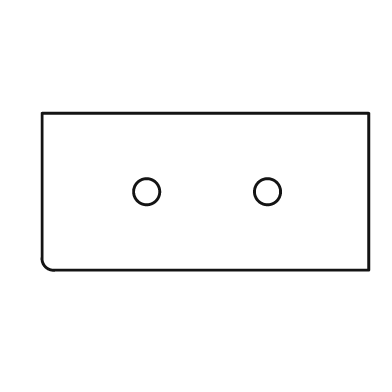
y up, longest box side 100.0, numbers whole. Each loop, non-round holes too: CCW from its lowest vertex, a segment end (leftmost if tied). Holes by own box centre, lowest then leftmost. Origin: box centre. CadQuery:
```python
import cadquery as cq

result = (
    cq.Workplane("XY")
    .moveTo(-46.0, -24.0)
    .lineTo(50.0, -24.0)
    .lineTo(50.0, 24.0)
    .lineTo(-50.0, 24.0)
    .lineTo(-50.0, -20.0)
    .threePointArc((-49.0, -23.0), (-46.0, -24.0))
    .close()
    .moveTo(-18.0, 0.0)
    .circle(4.0)
    .moveTo(19.0, 0.0)
    .circle(4.0)
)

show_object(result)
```